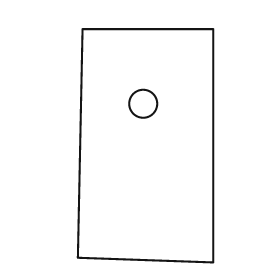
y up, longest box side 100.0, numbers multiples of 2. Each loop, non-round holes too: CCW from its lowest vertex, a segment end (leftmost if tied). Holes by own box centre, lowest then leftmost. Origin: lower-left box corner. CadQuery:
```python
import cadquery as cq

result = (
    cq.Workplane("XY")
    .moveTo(58.0, 0.0)
    .lineTo(58.0, 100.0)
    .lineTo(2.0, 100.0)
    .lineTo(0.0, 2.0)
    .close()
    .moveTo(28.0, 68.0)
    .circle(6.0)
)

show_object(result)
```